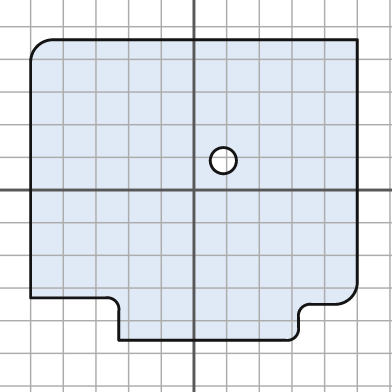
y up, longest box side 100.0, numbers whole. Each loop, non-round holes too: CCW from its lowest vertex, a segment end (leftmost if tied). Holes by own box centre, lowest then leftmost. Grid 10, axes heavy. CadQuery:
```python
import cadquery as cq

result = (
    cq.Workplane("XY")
    .moveTo(-23.0, -46.0)
    .lineTo(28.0, -46.0)
    .threePointArc((31.0, -45.0), (32.0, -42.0))
    .lineTo(32.0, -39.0)
    .threePointArc((33.0, -36.0), (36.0, -35.0))
    .lineTo(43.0, -35.0)
    .threePointArc((48.0, -33.0), (50.0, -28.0))
    .lineTo(50.0, 46.0)
    .lineTo(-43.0, 46.0)
    .threePointArc((-48.0, 44.0), (-50.0, 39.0))
    .lineTo(-50.0, -33.0)
    .lineTo(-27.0, -33.0)
    .threePointArc((-24.0, -34.0), (-23.0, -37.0))
    .close()
    .moveTo(9.0, 9.0)
    .circle(4.0)
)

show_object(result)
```